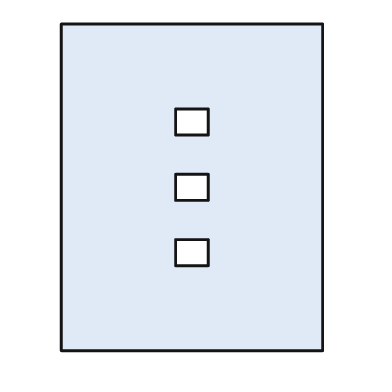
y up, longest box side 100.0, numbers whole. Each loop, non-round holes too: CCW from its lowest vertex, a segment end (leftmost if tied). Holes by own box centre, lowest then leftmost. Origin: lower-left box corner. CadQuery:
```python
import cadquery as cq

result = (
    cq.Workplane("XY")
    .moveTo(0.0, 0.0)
    .lineTo(80.0, 0.0)
    .lineTo(80.0, 100.0)
    .lineTo(0.0, 100.0)
    .close()
    .moveTo(35.0, 26.0)
    .lineTo(45.0, 26.0)
    .lineTo(45.0, 34.0)
    .lineTo(35.0, 34.0)
    .close()
    .moveTo(35.0, 46.0)
    .lineTo(45.0, 46.0)
    .lineTo(45.0, 54.0)
    .lineTo(35.0, 54.0)
    .close()
    .moveTo(35.0, 66.0)
    .lineTo(45.0, 66.0)
    .lineTo(45.0, 74.0)
    .lineTo(35.0, 74.0)
    .close()
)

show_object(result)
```